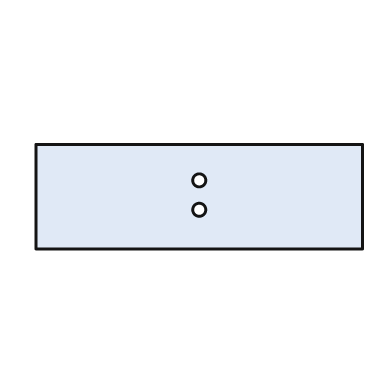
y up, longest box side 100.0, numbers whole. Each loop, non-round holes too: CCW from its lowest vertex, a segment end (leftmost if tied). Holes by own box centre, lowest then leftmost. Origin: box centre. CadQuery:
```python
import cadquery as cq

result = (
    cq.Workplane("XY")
    .moveTo(-50.0, -16.0)
    .lineTo(50.0, -16.0)
    .lineTo(50.0, 16.0)
    .lineTo(-50.0, 16.0)
    .close()
    .moveTo(0.0, -4.0)
    .circle(2.0)
    .moveTo(0.0, 5.0)
    .circle(2.0)
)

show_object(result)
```